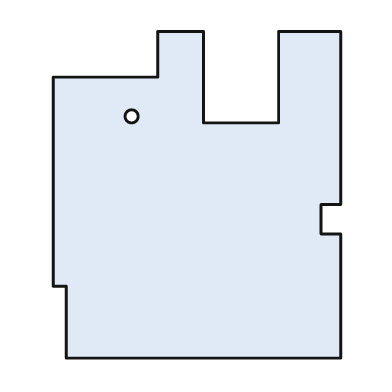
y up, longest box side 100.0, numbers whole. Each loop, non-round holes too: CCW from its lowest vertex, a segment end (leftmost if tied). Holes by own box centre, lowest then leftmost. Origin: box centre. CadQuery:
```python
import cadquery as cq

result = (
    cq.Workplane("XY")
    .moveTo(-40.0, -50.0)
    .lineTo(44.0, -50.0)
    .lineTo(44.0, -12.0)
    .lineTo(38.0, -12.0)
    .lineTo(38.0, -3.0)
    .lineTo(44.0, -3.0)
    .lineTo(44.0, 50.0)
    .lineTo(25.0, 50.0)
    .lineTo(25.0, 22.0)
    .lineTo(2.0, 22.0)
    .lineTo(2.0, 50.0)
    .lineTo(-12.0, 50.0)
    .lineTo(-12.0, 36.0)
    .lineTo(-44.0, 36.0)
    .lineTo(-44.0, -28.0)
    .lineTo(-40.0, -28.0)
    .close()
    .moveTo(-20.0, 24.0)
    .circle(2.0)
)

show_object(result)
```